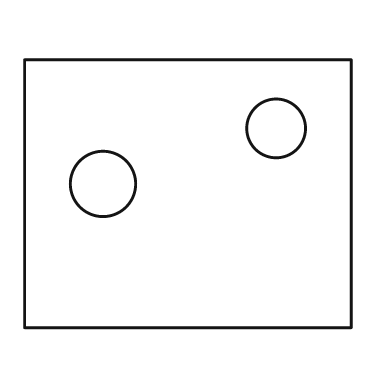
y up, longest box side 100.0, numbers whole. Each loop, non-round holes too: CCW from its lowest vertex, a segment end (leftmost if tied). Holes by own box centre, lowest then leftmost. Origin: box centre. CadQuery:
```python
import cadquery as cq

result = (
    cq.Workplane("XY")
    .moveTo(-50.0, -41.0)
    .lineTo(50.0, -41.0)
    .lineTo(50.0, 41.0)
    .lineTo(-50.0, 41.0)
    .close()
    .moveTo(-26.0, 3.0)
    .circle(10.0)
    .moveTo(27.0, 20.0)
    .circle(9.0)
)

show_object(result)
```